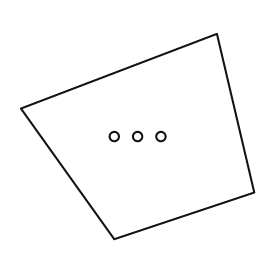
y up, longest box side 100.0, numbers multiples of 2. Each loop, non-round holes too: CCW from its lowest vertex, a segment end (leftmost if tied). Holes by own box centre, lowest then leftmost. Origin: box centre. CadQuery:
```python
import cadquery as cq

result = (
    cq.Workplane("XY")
    .moveTo(-10.0, -44.0)
    .lineTo(50.0, -24.0)
    .lineTo(34.0, 44.0)
    .lineTo(-50.0, 12.0)
    .close()
    .moveTo(-10.0, 0.0)
    .circle(2.0)
    .moveTo(0.0, 0.0)
    .circle(2.0)
    .moveTo(10.0, 0.0)
    .circle(2.0)
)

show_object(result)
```